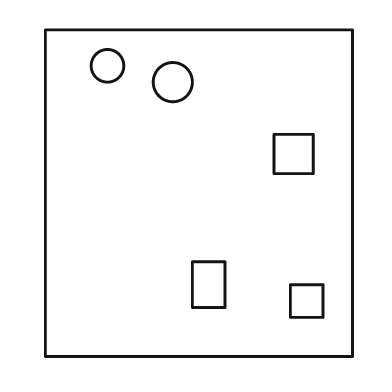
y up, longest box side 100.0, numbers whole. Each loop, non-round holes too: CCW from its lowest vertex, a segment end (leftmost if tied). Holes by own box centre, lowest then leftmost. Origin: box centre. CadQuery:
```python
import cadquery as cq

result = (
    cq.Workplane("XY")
    .moveTo(-47.0, -50.0)
    .lineTo(47.0, -50.0)
    .lineTo(47.0, 50.0)
    .lineTo(-47.0, 50.0)
    .close()
    .moveTo(28.0, -38.0)
    .lineTo(38.0, -38.0)
    .lineTo(38.0, -28.0)
    .lineTo(28.0, -28.0)
    .close()
    .moveTo(-2.0, -35.0)
    .lineTo(8.0, -35.0)
    .lineTo(8.0, -21.0)
    .lineTo(-2.0, -21.0)
    .close()
    .moveTo(23.0, 6.0)
    .lineTo(35.0, 6.0)
    .lineTo(35.0, 18.0)
    .lineTo(23.0, 18.0)
    .close()
    .moveTo(-8.0, 34.0)
    .circle(6.0)
    .moveTo(-28.0, 39.0)
    .circle(5.0)
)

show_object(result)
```